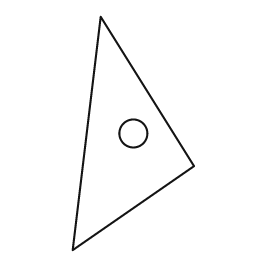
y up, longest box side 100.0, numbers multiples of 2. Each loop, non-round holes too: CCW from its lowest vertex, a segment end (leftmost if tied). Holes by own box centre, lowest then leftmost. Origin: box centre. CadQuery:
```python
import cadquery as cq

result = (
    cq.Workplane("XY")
    .moveTo(-26.0, -50.0)
    .lineTo(26.0, -14.0)
    .lineTo(-14.0, 50.0)
    .close()
    .moveTo(0.0, 0.0)
    .circle(6.0)
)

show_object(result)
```